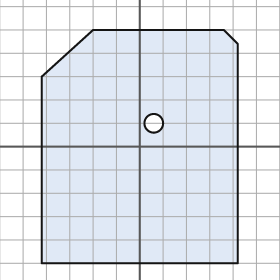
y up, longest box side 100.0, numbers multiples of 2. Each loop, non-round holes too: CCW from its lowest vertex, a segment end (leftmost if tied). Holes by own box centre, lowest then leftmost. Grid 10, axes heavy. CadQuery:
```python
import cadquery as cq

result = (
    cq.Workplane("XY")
    .moveTo(-42.0, -50.0)
    .lineTo(42.0, -50.0)
    .lineTo(42.0, 44.0)
    .lineTo(36.0, 50.0)
    .lineTo(-20.0, 50.0)
    .lineTo(-42.0, 30.0)
    .close()
    .moveTo(6.0, 10.0)
    .circle(4.0)
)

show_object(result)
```